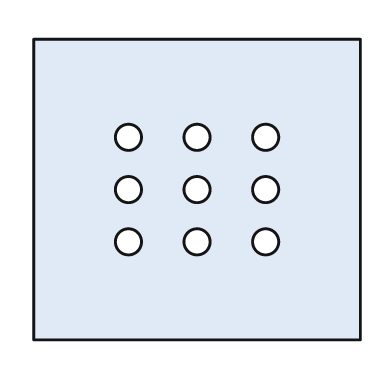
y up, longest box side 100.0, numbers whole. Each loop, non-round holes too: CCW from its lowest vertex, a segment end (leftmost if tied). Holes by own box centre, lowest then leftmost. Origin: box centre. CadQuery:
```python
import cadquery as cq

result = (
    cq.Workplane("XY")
    .moveTo(-50.0, -46.0)
    .lineTo(50.0, -46.0)
    .lineTo(50.0, 46.0)
    .lineTo(-50.0, 46.0)
    .close()
    .moveTo(-21.0, -16.0)
    .circle(4.0)
    .moveTo(0.0, -16.0)
    .circle(4.0)
    .moveTo(21.0, -16.0)
    .circle(4.0)
    .moveTo(-21.0, 0.0)
    .circle(4.0)
    .moveTo(0.0, 0.0)
    .circle(4.0)
    .moveTo(21.0, 0.0)
    .circle(4.0)
    .moveTo(-21.0, 16.0)
    .circle(4.0)
    .moveTo(0.0, 16.0)
    .circle(4.0)
    .moveTo(21.0, 16.0)
    .circle(4.0)
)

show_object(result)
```